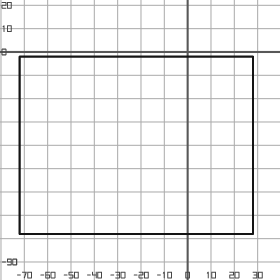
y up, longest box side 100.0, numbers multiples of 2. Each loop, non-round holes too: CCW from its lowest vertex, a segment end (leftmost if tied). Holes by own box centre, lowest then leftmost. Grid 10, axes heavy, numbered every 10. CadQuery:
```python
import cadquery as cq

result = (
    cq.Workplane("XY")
    .moveTo(-72.0, -78.0)
    .lineTo(28.0, -78.0)
    .lineTo(28.0, -2.0)
    .lineTo(-72.0, -2.0)
    .close()
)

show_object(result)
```